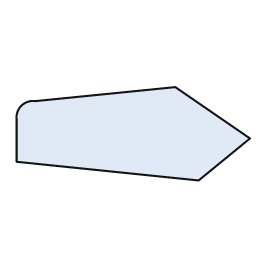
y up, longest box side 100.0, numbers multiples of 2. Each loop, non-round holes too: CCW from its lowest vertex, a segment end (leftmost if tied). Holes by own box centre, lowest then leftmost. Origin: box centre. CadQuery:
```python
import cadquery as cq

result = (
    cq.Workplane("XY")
    .moveTo(28.0, -20.0)
    .lineTo(50.0, -2.0)
    .lineTo(18.0, 20.0)
    .lineTo(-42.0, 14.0)
    .threePointArc((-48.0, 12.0), (-50.0, 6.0))
    .lineTo(-50.0, -12.0)
    .close()
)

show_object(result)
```